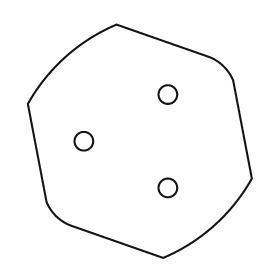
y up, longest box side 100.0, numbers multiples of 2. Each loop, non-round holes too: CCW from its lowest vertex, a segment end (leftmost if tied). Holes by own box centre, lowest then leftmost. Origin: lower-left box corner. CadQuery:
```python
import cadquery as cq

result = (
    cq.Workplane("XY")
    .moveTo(58.0, 0.0)
    .threePointArc((80.0, 14.0), (96.0, 34.0))
    .lineTo(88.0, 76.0)
    .threePointArc((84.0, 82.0), (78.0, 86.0))
    .lineTo(38.0, 100.0)
    .threePointArc((16.0, 86.0), (0.0, 66.0))
    .lineTo(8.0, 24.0)
    .threePointArc((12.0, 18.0), (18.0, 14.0))
    .close()
    .moveTo(60.0, 30.0)
    .circle(4.0)
    .moveTo(24.0, 50.0)
    .circle(4.0)
    .moveTo(60.0, 70.0)
    .circle(4.0)
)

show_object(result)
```